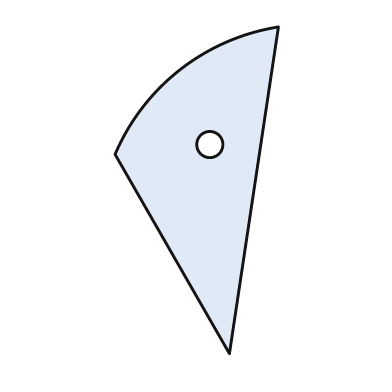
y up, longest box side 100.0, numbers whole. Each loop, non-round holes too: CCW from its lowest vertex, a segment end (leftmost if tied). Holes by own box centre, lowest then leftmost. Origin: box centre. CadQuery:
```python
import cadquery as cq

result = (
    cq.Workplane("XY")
    .moveTo(10.0, -50.0)
    .lineTo(25.0, 50.0)
    .threePointArc((-5.0, 37.0), (-25.0, 11.0))
    .close()
    .moveTo(4.0, 14.0)
    .circle(4.0)
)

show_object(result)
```